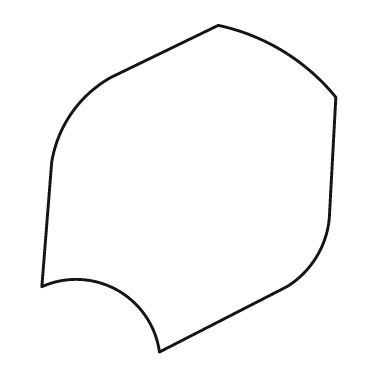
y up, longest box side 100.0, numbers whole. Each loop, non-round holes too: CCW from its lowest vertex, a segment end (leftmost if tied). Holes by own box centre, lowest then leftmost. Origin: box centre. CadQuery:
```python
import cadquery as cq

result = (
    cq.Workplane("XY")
    .moveTo(-9.0, -50.0)
    .lineTo(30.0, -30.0)
    .threePointArc((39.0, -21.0), (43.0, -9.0))
    .lineTo(45.0, 28.0)
    .threePointArc((29.0, 42.0), (9.0, 50.0))
    .lineTo(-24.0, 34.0)
    .threePointArc((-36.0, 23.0), (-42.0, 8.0))
    .lineTo(-45.0, -30.0)
    .threePointArc((-22.0, -31.0), (-9.0, -50.0))
    .close()
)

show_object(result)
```